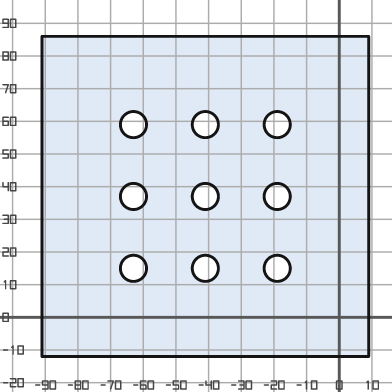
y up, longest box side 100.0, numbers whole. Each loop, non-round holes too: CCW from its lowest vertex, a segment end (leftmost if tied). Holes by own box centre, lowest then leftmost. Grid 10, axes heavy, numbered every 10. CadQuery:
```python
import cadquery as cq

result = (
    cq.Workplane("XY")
    .moveTo(-91.0, -12.0)
    .lineTo(9.0, -12.0)
    .lineTo(9.0, 86.0)
    .lineTo(-91.0, 86.0)
    .close()
    .moveTo(-63.0, 15.0)
    .circle(4.0)
    .moveTo(-41.0, 15.0)
    .circle(4.0)
    .moveTo(-19.0, 15.0)
    .circle(4.0)
    .moveTo(-63.0, 37.0)
    .circle(4.0)
    .moveTo(-41.0, 37.0)
    .circle(4.0)
    .moveTo(-19.0, 37.0)
    .circle(4.0)
    .moveTo(-63.0, 59.0)
    .circle(4.0)
    .moveTo(-41.0, 59.0)
    .circle(4.0)
    .moveTo(-19.0, 59.0)
    .circle(4.0)
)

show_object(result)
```